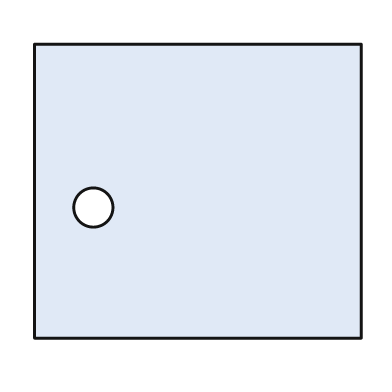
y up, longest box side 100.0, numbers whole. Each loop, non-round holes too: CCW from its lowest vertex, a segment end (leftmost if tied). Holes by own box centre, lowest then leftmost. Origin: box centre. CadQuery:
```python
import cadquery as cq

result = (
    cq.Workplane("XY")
    .moveTo(-50.0, -45.0)
    .lineTo(50.0, -45.0)
    .lineTo(50.0, 45.0)
    .lineTo(-50.0, 45.0)
    .close()
    .moveTo(-32.0, -5.0)
    .circle(6.0)
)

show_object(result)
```